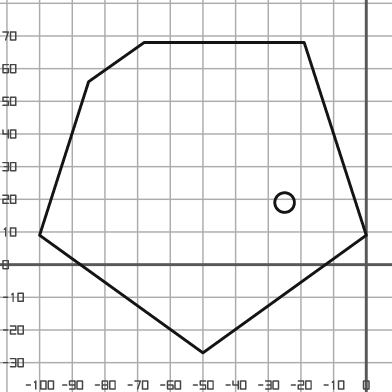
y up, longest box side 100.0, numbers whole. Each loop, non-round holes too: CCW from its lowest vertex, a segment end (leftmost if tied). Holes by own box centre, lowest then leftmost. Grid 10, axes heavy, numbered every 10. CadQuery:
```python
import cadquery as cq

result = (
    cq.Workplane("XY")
    .moveTo(-50.0, -27.0)
    .lineTo(0.0, 9.0)
    .lineTo(-19.0, 68.0)
    .lineTo(-68.0, 68.0)
    .lineTo(-85.0, 56.0)
    .lineTo(-100.0, 9.0)
    .close()
    .moveTo(-25.0, 19.0)
    .circle(3.0)
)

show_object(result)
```